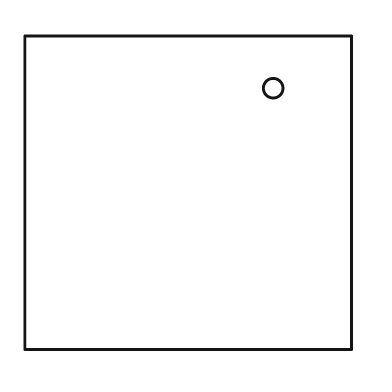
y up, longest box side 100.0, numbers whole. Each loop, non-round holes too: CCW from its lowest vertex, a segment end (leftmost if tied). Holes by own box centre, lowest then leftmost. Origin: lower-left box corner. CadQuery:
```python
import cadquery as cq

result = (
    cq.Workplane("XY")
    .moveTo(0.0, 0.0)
    .lineTo(100.0, 0.0)
    .lineTo(100.0, 96.0)
    .lineTo(0.0, 96.0)
    .close()
    .moveTo(76.0, 80.0)
    .circle(3.0)
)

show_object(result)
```